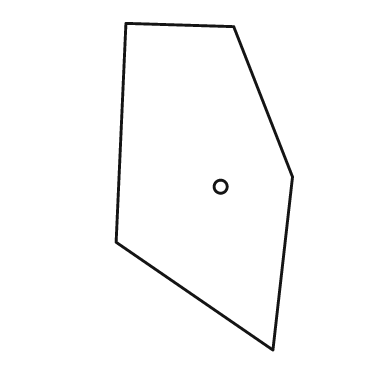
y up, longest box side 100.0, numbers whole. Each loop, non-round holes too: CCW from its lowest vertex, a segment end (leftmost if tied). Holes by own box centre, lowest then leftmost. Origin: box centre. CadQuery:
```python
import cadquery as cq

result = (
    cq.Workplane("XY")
    .moveTo(21.0, -50.0)
    .lineTo(27.0, 3.0)
    .lineTo(9.0, 49.0)
    .lineTo(-24.0, 50.0)
    .lineTo(-27.0, -17.0)
    .close()
    .moveTo(5.0, 0.0)
    .circle(2.0)
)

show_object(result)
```